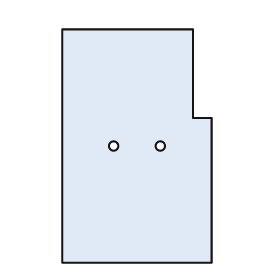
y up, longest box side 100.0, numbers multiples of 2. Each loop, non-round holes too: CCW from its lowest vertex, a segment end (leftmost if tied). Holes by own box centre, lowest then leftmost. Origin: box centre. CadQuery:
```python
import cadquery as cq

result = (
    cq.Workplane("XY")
    .moveTo(-32.0, -50.0)
    .lineTo(32.0, -50.0)
    .lineTo(32.0, 12.0)
    .lineTo(24.0, 12.0)
    .lineTo(24.0, 50.0)
    .lineTo(-32.0, 50.0)
    .close()
    .moveTo(-10.0, 0.0)
    .circle(2.0)
    .moveTo(10.0, 0.0)
    .circle(2.0)
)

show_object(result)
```